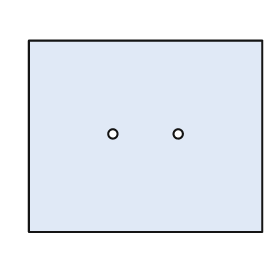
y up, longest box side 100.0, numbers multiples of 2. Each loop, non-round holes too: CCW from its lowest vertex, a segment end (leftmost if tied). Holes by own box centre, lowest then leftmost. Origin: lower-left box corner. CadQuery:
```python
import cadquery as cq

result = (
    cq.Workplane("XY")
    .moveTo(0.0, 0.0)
    .lineTo(100.0, 0.0)
    .lineTo(100.0, 82.0)
    .lineTo(0.0, 82.0)
    .close()
    .moveTo(36.0, 42.0)
    .circle(2.0)
    .moveTo(64.0, 42.0)
    .circle(2.0)
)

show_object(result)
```